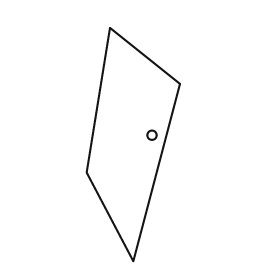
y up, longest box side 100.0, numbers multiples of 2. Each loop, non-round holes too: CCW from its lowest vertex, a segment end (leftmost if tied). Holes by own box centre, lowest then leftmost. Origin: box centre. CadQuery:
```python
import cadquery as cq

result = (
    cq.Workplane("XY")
    .moveTo(0.0, -50.0)
    .lineTo(20.0, 26.0)
    .lineTo(-10.0, 50.0)
    .lineTo(-20.0, -12.0)
    .close()
    .moveTo(8.0, 4.0)
    .circle(2.0)
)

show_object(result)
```